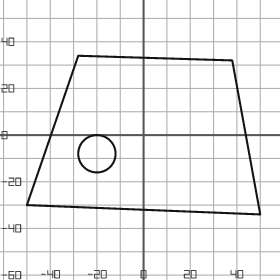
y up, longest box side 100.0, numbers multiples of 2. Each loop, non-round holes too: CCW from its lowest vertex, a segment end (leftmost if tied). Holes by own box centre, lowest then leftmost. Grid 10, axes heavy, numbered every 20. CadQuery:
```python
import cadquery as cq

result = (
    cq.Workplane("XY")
    .moveTo(50.0, -34.0)
    .lineTo(38.0, 32.0)
    .lineTo(-28.0, 34.0)
    .lineTo(-50.0, -30.0)
    .close()
    .moveTo(-20.0, -8.0)
    .circle(8.0)
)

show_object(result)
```